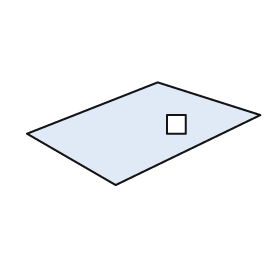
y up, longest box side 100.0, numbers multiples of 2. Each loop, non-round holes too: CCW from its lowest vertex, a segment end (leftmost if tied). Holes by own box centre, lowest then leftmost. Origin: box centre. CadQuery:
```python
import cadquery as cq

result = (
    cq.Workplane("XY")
    .moveTo(-12.0, -22.0)
    .lineTo(50.0, 8.0)
    .lineTo(6.0, 22.0)
    .lineTo(-50.0, 0.0)
    .close()
    .moveTo(10.0, 0.0)
    .lineTo(18.0, 0.0)
    .lineTo(18.0, 8.0)
    .lineTo(10.0, 8.0)
    .close()
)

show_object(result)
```